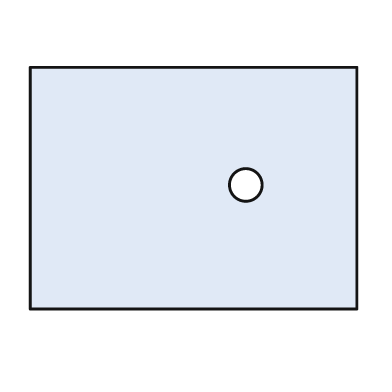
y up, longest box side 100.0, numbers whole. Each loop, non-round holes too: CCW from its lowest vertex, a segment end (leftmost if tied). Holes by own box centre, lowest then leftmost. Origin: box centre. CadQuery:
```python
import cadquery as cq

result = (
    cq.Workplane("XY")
    .moveTo(-50.0, -37.0)
    .lineTo(50.0, -37.0)
    .lineTo(50.0, 37.0)
    .lineTo(-50.0, 37.0)
    .close()
    .moveTo(16.0, 1.0)
    .circle(5.0)
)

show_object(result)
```